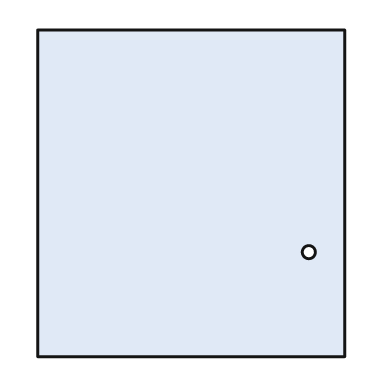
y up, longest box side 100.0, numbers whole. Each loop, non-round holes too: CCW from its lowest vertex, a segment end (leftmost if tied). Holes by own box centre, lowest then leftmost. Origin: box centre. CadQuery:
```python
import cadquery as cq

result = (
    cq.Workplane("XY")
    .moveTo(-47.0, -50.0)
    .lineTo(47.0, -50.0)
    .lineTo(47.0, 50.0)
    .lineTo(-47.0, 50.0)
    .close()
    .moveTo(36.0, -18.0)
    .circle(2.0)
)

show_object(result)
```